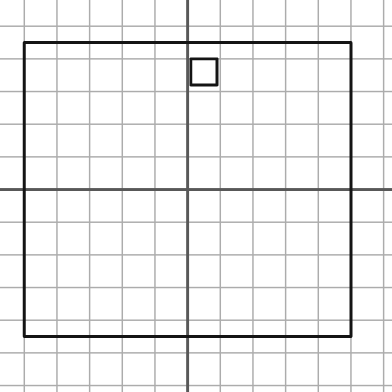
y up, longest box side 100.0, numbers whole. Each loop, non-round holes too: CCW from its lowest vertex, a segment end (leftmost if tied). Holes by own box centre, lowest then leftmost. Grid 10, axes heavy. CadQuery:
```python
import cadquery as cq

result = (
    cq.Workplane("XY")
    .moveTo(-50.0, -45.0)
    .lineTo(50.0, -45.0)
    .lineTo(50.0, 45.0)
    .lineTo(-50.0, 45.0)
    .close()
    .moveTo(1.0, 32.0)
    .lineTo(9.0, 32.0)
    .lineTo(9.0, 40.0)
    .lineTo(1.0, 40.0)
    .close()
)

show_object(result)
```